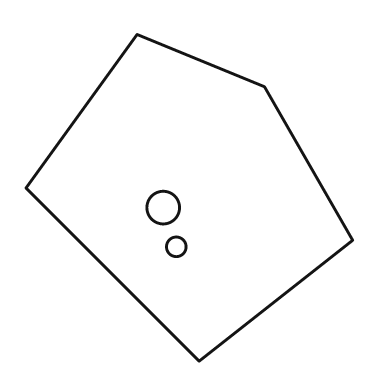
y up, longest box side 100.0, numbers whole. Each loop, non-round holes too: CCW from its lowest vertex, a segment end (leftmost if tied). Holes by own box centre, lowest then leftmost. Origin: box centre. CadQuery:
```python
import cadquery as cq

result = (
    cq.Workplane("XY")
    .moveTo(3.0, -50.0)
    .lineTo(50.0, -13.0)
    .lineTo(23.0, 34.0)
    .lineTo(-16.0, 50.0)
    .lineTo(-50.0, 3.0)
    .close()
    .moveTo(-4.0, -15.0)
    .circle(3.0)
    .moveTo(-8.0, -3.0)
    .circle(5.0)
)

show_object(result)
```